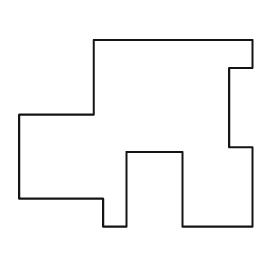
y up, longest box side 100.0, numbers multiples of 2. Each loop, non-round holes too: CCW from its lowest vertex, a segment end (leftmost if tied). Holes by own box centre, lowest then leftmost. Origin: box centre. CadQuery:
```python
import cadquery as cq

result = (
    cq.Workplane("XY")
    .moveTo(-14.0, -40.0)
    .lineTo(-4.0, -40.0)
    .lineTo(-4.0, -8.0)
    .lineTo(20.0, -8.0)
    .lineTo(20.0, -40.0)
    .lineTo(50.0, -40.0)
    .lineTo(50.0, -6.0)
    .lineTo(40.0, -6.0)
    .lineTo(40.0, 28.0)
    .lineTo(50.0, 28.0)
    .lineTo(50.0, 40.0)
    .lineTo(-18.0, 40.0)
    .lineTo(-18.0, 8.0)
    .lineTo(-50.0, 8.0)
    .lineTo(-50.0, -28.0)
    .lineTo(-14.0, -28.0)
    .close()
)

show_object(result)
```